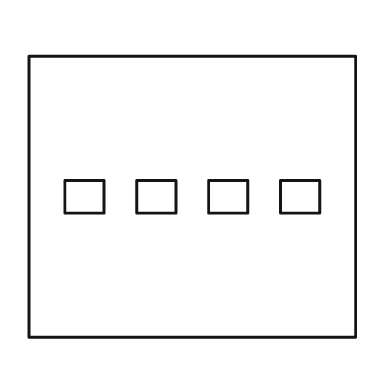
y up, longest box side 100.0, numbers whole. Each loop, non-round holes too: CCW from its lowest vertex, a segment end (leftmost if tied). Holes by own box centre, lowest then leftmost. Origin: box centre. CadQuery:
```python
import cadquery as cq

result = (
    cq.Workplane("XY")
    .moveTo(-50.0, -43.0)
    .lineTo(50.0, -43.0)
    .lineTo(50.0, 43.0)
    .lineTo(-50.0, 43.0)
    .close()
    .moveTo(-39.0, -5.0)
    .lineTo(-27.0, -5.0)
    .lineTo(-27.0, 5.0)
    .lineTo(-39.0, 5.0)
    .close()
    .moveTo(-17.0, -5.0)
    .lineTo(-5.0, -5.0)
    .lineTo(-5.0, 5.0)
    .lineTo(-17.0, 5.0)
    .close()
    .moveTo(5.0, -5.0)
    .lineTo(17.0, -5.0)
    .lineTo(17.0, 5.0)
    .lineTo(5.0, 5.0)
    .close()
    .moveTo(27.0, -5.0)
    .lineTo(39.0, -5.0)
    .lineTo(39.0, 5.0)
    .lineTo(27.0, 5.0)
    .close()
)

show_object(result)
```